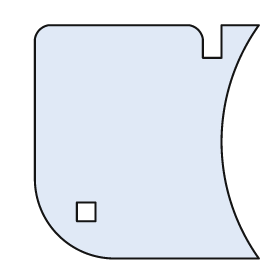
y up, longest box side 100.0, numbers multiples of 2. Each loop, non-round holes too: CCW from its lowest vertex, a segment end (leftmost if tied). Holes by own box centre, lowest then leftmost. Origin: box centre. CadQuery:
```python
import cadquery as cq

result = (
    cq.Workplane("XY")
    .moveTo(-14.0, -50.0)
    .lineTo(48.0, -50.0)
    .threePointArc((32.0, 0.0), (48.0, 50.0))
    .lineTo(32.0, 50.0)
    .lineTo(32.0, 36.0)
    .lineTo(24.0, 36.0)
    .lineTo(24.0, 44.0)
    .threePointArc((22.0, 48.0), (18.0, 50.0))
    .lineTo(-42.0, 50.0)
    .threePointArc((-46.0, 48.0), (-48.0, 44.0))
    .lineTo(-48.0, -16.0)
    .threePointArc((-38.0, -40.0), (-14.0, -50.0))
    .close()
    .moveTo(-30.0, -34.0)
    .lineTo(-22.0, -34.0)
    .lineTo(-22.0, -26.0)
    .lineTo(-30.0, -26.0)
    .close()
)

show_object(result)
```